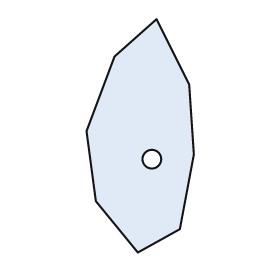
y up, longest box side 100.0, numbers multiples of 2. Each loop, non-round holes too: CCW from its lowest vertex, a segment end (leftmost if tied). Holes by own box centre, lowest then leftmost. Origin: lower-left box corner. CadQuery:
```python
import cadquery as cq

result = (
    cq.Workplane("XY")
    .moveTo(22.0, 0.0)
    .lineTo(40.0, 10.0)
    .lineTo(46.0, 42.0)
    .lineTo(44.0, 72.0)
    .lineTo(30.0, 100.0)
    .lineTo(12.0, 84.0)
    .lineTo(0.0, 52.0)
    .lineTo(4.0, 22.0)
    .close()
    .moveTo(28.0, 40.0)
    .circle(4.0)
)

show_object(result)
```